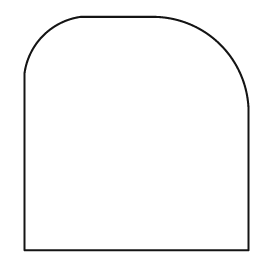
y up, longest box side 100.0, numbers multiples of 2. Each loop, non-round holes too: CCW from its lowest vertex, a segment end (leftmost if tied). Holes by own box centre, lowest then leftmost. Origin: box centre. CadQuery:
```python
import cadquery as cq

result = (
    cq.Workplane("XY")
    .moveTo(-48.0, -50.0)
    .lineTo(48.0, -50.0)
    .lineTo(48.0, 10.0)
    .threePointArc((36.0, 38.0), (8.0, 50.0))
    .lineTo(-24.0, 50.0)
    .threePointArc((-40.0, 42.0), (-48.0, 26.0))
    .close()
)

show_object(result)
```